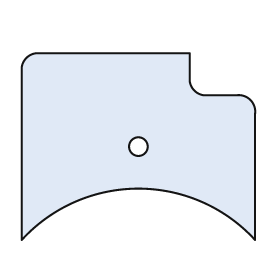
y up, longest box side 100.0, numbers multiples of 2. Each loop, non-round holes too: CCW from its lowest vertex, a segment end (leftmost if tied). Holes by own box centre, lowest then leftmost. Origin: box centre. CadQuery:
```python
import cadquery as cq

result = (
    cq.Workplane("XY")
    .moveTo(-50.0, -40.0)
    .threePointArc((0.0, -18.0), (50.0, -40.0))
    .lineTo(50.0, 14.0)
    .threePointArc((48.0, 20.0), (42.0, 22.0))
    .lineTo(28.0, 22.0)
    .threePointArc((24.0, 24.0), (22.0, 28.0))
    .lineTo(22.0, 40.0)
    .lineTo(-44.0, 40.0)
    .threePointArc((-48.0, 38.0), (-50.0, 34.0))
    .close()
    .moveTo(0.0, 0.0)
    .circle(4.0)
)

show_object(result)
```